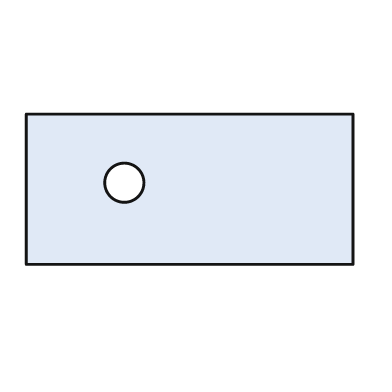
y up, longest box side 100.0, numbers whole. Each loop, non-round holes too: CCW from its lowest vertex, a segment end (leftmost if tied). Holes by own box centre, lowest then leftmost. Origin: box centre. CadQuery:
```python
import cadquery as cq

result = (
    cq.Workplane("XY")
    .moveTo(-50.0, -23.0)
    .lineTo(50.0, -23.0)
    .lineTo(50.0, 23.0)
    .lineTo(-50.0, 23.0)
    .close()
    .moveTo(-20.0, 2.0)
    .circle(6.0)
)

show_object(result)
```